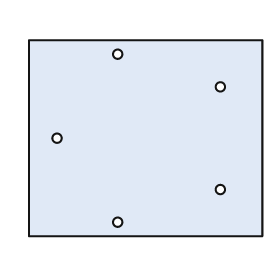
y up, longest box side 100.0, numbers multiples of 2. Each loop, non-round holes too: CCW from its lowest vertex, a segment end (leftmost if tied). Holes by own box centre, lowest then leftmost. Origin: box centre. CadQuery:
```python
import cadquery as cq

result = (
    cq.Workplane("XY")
    .moveTo(-50.0, -42.0)
    .lineTo(50.0, -42.0)
    .lineTo(50.0, 42.0)
    .lineTo(-50.0, 42.0)
    .close()
    .moveTo(-12.0, -36.0)
    .circle(2.0)
    .moveTo(32.0, -22.0)
    .circle(2.0)
    .moveTo(-38.0, 0.0)
    .circle(2.0)
    .moveTo(32.0, 22.0)
    .circle(2.0)
    .moveTo(-12.0, 36.0)
    .circle(2.0)
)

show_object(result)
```